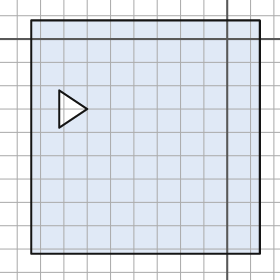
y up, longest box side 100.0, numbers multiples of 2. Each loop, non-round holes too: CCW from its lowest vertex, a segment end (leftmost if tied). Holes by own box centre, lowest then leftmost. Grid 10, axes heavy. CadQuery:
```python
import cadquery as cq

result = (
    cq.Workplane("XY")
    .moveTo(-84.0, -92.0)
    .lineTo(14.0, -92.0)
    .lineTo(14.0, 8.0)
    .lineTo(-84.0, 8.0)
    .close()
    .moveTo(-72.0, -38.0)
    .lineTo(-60.0, -30.0)
    .lineTo(-72.0, -22.0)
    .close()
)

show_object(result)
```